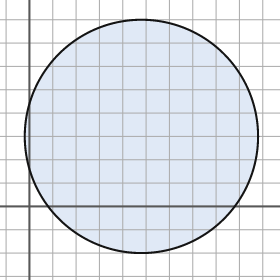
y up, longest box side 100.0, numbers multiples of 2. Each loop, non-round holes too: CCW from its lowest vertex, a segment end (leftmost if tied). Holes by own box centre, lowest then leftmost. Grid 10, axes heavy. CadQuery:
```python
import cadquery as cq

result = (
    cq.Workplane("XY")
    .moveTo(48.0, 30.0)
    .circle(50.0)
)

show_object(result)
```